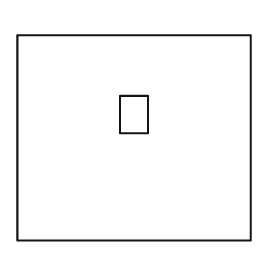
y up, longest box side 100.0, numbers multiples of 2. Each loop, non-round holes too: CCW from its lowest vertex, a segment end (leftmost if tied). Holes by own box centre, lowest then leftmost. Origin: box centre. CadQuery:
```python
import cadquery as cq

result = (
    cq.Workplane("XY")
    .moveTo(-50.0, -44.0)
    .lineTo(50.0, -44.0)
    .lineTo(50.0, 44.0)
    .lineTo(-50.0, 44.0)
    .close()
    .moveTo(-6.0, 2.0)
    .lineTo(6.0, 2.0)
    .lineTo(6.0, 18.0)
    .lineTo(-6.0, 18.0)
    .close()
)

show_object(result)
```